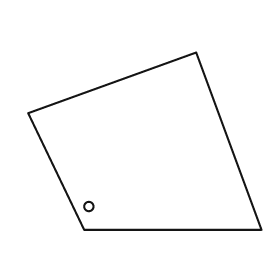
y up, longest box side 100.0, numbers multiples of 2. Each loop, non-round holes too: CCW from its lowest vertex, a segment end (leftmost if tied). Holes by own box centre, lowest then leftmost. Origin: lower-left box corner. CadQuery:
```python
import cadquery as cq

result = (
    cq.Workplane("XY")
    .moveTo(24.0, 0.0)
    .lineTo(100.0, 0.0)
    .lineTo(72.0, 76.0)
    .lineTo(0.0, 50.0)
    .close()
    .moveTo(26.0, 10.0)
    .circle(2.0)
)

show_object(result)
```